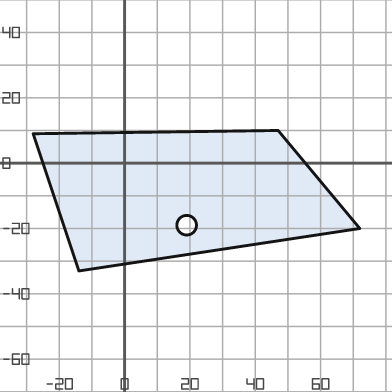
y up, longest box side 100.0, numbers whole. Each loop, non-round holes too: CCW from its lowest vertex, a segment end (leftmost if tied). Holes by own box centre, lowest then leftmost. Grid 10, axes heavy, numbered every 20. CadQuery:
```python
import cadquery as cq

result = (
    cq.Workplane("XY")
    .moveTo(-14.0, -33.0)
    .lineTo(72.0, -20.0)
    .lineTo(47.0, 10.0)
    .lineTo(-28.0, 9.0)
    .close()
    .moveTo(19.0, -19.0)
    .circle(3.0)
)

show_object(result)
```